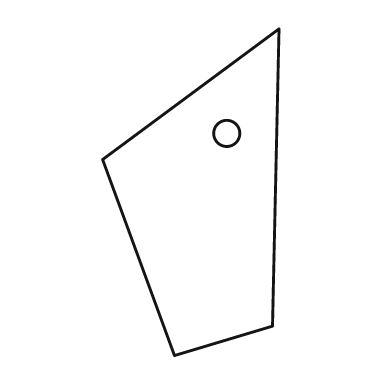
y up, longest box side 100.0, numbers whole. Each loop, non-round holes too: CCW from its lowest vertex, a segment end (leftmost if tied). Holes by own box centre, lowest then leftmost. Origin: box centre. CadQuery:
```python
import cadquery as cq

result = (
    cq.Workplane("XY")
    .moveTo(-5.0, -50.0)
    .lineTo(25.0, -41.0)
    .lineTo(27.0, 50.0)
    .lineTo(-27.0, 10.0)
    .close()
    .moveTo(11.0, 18.0)
    .circle(4.0)
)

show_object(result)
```